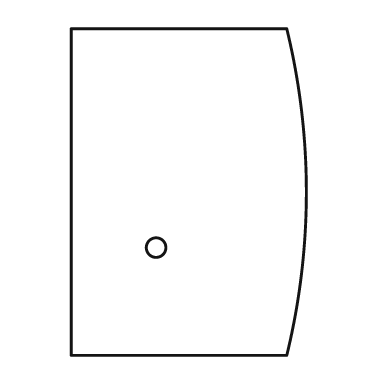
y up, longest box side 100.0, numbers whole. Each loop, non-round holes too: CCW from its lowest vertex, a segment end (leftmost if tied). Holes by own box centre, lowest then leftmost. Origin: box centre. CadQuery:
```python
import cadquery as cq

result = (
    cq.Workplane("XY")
    .moveTo(-36.0, -50.0)
    .lineTo(30.0, -50.0)
    .threePointArc((36.0, 0.0), (30.0, 50.0))
    .lineTo(-36.0, 50.0)
    .close()
    .moveTo(-10.0, -17.0)
    .circle(3.0)
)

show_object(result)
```